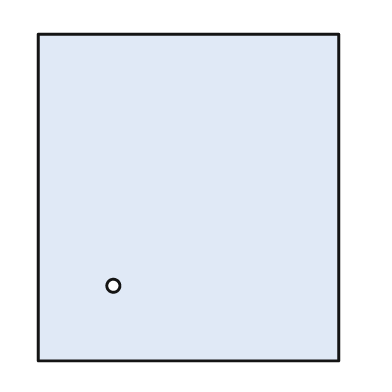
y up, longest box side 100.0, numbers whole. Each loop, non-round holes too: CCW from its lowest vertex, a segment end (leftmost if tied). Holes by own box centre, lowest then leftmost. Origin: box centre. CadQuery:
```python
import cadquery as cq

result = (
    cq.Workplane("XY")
    .moveTo(-46.0, -50.0)
    .lineTo(46.0, -50.0)
    .lineTo(46.0, 50.0)
    .lineTo(-46.0, 50.0)
    .close()
    .moveTo(-23.0, -27.0)
    .circle(2.0)
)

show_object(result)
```